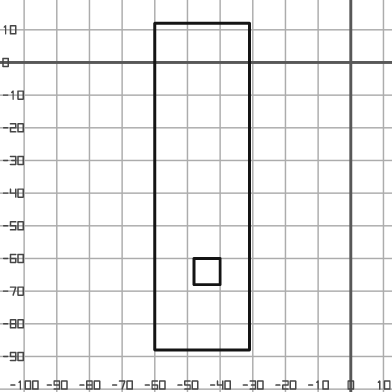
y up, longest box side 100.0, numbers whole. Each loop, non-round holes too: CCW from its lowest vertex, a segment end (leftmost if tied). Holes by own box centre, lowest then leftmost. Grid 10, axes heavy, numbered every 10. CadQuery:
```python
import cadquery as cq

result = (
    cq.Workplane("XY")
    .moveTo(-60.0, -88.0)
    .lineTo(-31.0, -88.0)
    .lineTo(-31.0, 12.0)
    .lineTo(-60.0, 12.0)
    .close()
    .moveTo(-48.0, -68.0)
    .lineTo(-40.0, -68.0)
    .lineTo(-40.0, -60.0)
    .lineTo(-48.0, -60.0)
    .close()
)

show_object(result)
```